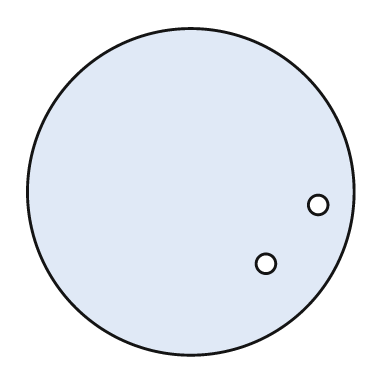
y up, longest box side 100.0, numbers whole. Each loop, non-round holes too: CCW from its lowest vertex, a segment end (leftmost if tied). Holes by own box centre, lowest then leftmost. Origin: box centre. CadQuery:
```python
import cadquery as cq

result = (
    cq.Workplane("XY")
    .moveTo(0.0, 0.0)
    .circle(50.0)
    .moveTo(23.0, -22.0)
    .circle(3.0)
    .moveTo(39.0, -4.0)
    .circle(3.0)
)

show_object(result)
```